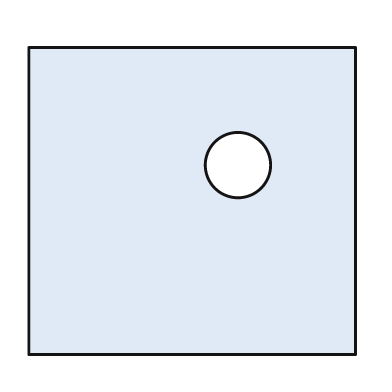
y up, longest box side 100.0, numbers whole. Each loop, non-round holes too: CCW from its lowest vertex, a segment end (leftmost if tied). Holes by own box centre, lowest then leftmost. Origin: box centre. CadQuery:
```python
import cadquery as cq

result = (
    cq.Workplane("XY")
    .moveTo(-50.0, -47.0)
    .lineTo(50.0, -47.0)
    .lineTo(50.0, 47.0)
    .lineTo(-50.0, 47.0)
    .close()
    .moveTo(14.0, 11.0)
    .circle(10.0)
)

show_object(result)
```